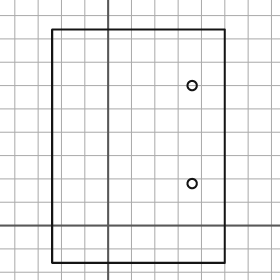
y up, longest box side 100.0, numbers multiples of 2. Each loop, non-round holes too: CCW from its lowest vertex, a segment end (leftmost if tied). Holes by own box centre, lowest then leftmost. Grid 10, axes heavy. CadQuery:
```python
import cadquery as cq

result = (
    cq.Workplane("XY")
    .moveTo(-24.0, -16.0)
    .lineTo(50.0, -16.0)
    .lineTo(50.0, 84.0)
    .lineTo(-24.0, 84.0)
    .close()
    .moveTo(36.0, 18.0)
    .circle(2.0)
    .moveTo(36.0, 60.0)
    .circle(2.0)
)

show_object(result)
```